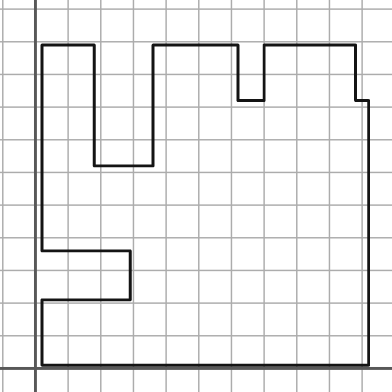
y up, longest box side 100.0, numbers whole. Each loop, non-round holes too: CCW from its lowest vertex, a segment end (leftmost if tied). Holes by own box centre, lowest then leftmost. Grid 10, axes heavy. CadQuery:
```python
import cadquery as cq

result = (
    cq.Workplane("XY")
    .moveTo(2.0, 1.0)
    .lineTo(102.0, 1.0)
    .lineTo(102.0, 82.0)
    .lineTo(98.0, 82.0)
    .lineTo(98.0, 99.0)
    .lineTo(70.0, 99.0)
    .lineTo(70.0, 82.0)
    .lineTo(62.0, 82.0)
    .lineTo(62.0, 99.0)
    .lineTo(36.0, 99.0)
    .lineTo(36.0, 62.0)
    .lineTo(18.0, 62.0)
    .lineTo(18.0, 99.0)
    .lineTo(2.0, 99.0)
    .lineTo(2.0, 36.0)
    .lineTo(29.0, 36.0)
    .lineTo(29.0, 21.0)
    .lineTo(2.0, 21.0)
    .close()
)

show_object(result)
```